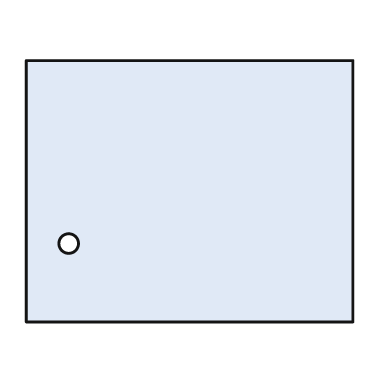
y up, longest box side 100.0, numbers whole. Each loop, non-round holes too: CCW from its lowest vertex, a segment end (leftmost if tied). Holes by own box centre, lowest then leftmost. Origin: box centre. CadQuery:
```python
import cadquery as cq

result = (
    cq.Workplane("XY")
    .moveTo(-50.0, -40.0)
    .lineTo(50.0, -40.0)
    .lineTo(50.0, 40.0)
    .lineTo(-50.0, 40.0)
    .close()
    .moveTo(-37.0, -16.0)
    .circle(3.0)
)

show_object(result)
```